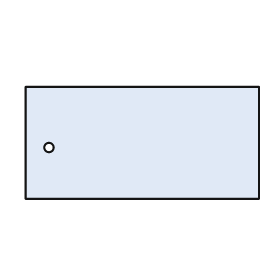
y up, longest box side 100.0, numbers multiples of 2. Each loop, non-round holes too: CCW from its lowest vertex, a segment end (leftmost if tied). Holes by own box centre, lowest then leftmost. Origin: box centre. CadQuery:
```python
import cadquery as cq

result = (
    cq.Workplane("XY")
    .moveTo(-50.0, -24.0)
    .lineTo(50.0, -24.0)
    .lineTo(50.0, 24.0)
    .lineTo(-50.0, 24.0)
    .close()
    .moveTo(-40.0, -2.0)
    .circle(2.0)
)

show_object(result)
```